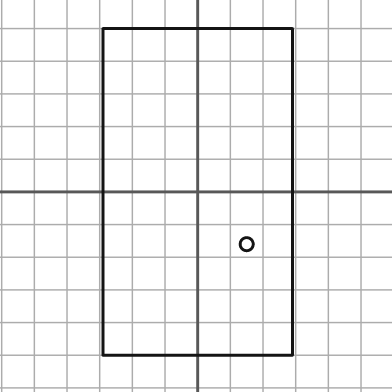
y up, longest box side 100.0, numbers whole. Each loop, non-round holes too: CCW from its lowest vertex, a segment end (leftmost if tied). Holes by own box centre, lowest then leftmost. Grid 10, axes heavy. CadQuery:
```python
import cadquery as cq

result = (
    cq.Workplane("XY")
    .moveTo(-29.0, -50.0)
    .lineTo(29.0, -50.0)
    .lineTo(29.0, 50.0)
    .lineTo(-29.0, 50.0)
    .close()
    .moveTo(15.0, -16.0)
    .circle(2.0)
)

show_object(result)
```